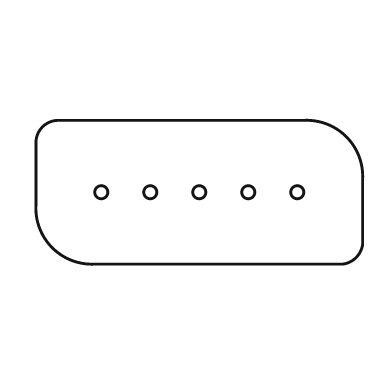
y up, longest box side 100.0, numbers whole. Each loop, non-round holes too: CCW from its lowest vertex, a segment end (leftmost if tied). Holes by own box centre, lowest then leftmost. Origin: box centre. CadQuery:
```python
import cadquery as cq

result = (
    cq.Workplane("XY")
    .moveTo(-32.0, -22.0)
    .lineTo(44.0, -22.0)
    .threePointArc((48.0, -20.0), (50.0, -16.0))
    .lineTo(50.0, 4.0)
    .threePointArc((45.0, 17.0), (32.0, 22.0))
    .lineTo(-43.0, 22.0)
    .threePointArc((-48.0, 20.0), (-50.0, 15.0))
    .lineTo(-50.0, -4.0)
    .threePointArc((-45.0, -17.0), (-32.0, -22.0))
    .close()
    .moveTo(-30.0, 0.0)
    .circle(2.0)
    .moveTo(-15.0, 0.0)
    .circle(2.0)
    .moveTo(0.0, 0.0)
    .circle(2.0)
    .moveTo(15.0, 0.0)
    .circle(2.0)
    .moveTo(30.0, 0.0)
    .circle(2.0)
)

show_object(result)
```